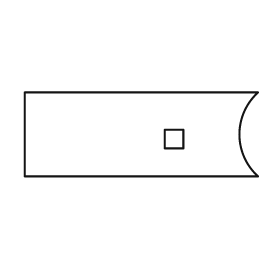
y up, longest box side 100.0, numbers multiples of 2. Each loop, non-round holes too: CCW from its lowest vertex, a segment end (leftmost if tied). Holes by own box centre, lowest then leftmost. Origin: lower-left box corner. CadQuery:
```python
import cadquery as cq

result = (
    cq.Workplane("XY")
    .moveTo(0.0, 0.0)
    .lineTo(100.0, 0.0)
    .threePointArc((92.0, 18.0), (100.0, 36.0))
    .lineTo(0.0, 36.0)
    .close()
    .moveTo(60.0, 12.0)
    .lineTo(68.0, 12.0)
    .lineTo(68.0, 20.0)
    .lineTo(60.0, 20.0)
    .close()
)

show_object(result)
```